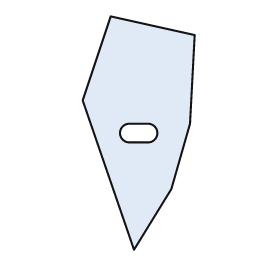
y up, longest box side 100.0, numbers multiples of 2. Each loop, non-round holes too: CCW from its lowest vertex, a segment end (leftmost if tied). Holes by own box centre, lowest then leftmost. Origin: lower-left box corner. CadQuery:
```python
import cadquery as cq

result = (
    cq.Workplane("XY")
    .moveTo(22.0, 0.0)
    .lineTo(38.0, 26.0)
    .lineTo(46.0, 54.0)
    .lineTo(48.0, 92.0)
    .lineTo(12.0, 100.0)
    .lineTo(0.0, 64.0)
    .close()
    .moveTo(20.0, 46.0)
    .lineTo(28.0, 46.0)
    .threePointArc((32.0, 50.0), (28.0, 54.0))
    .lineTo(20.0, 54.0)
    .threePointArc((16.0, 50.0), (20.0, 46.0))
    .close()
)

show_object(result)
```